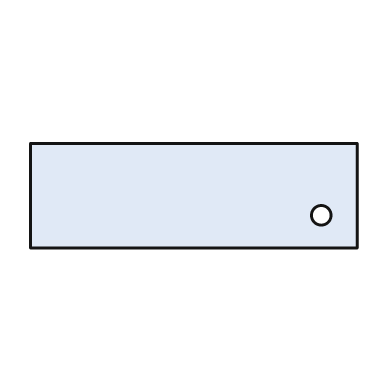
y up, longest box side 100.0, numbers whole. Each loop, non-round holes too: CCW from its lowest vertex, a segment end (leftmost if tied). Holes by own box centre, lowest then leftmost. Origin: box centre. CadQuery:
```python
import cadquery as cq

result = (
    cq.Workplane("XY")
    .moveTo(-50.0, -16.0)
    .lineTo(50.0, -16.0)
    .lineTo(50.0, 16.0)
    .lineTo(-50.0, 16.0)
    .close()
    .moveTo(39.0, -6.0)
    .circle(3.0)
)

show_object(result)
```